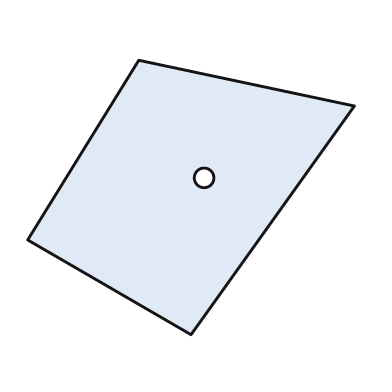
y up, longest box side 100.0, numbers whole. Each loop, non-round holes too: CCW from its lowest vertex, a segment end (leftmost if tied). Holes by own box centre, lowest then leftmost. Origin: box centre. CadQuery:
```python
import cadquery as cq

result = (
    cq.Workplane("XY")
    .moveTo(0.0, -42.0)
    .lineTo(50.0, 28.0)
    .lineTo(-16.0, 42.0)
    .lineTo(-50.0, -13.0)
    .close()
    .moveTo(4.0, 6.0)
    .circle(3.0)
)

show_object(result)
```